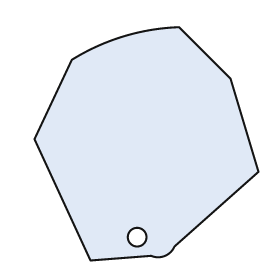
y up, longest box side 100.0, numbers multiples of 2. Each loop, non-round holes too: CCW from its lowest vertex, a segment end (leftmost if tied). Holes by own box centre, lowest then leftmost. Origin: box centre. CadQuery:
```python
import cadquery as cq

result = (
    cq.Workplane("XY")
    .moveTo(-24.0, -50.0)
    .lineTo(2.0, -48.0)
    .threePointArc((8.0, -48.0), (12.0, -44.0))
    .lineTo(48.0, -12.0)
    .lineTo(36.0, 28.0)
    .lineTo(14.0, 50.0)
    .threePointArc((-10.0, 46.0), (-32.0, 36.0))
    .lineTo(-48.0, 2.0)
    .close()
    .moveTo(-4.0, -40.0)
    .circle(4.0)
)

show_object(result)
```